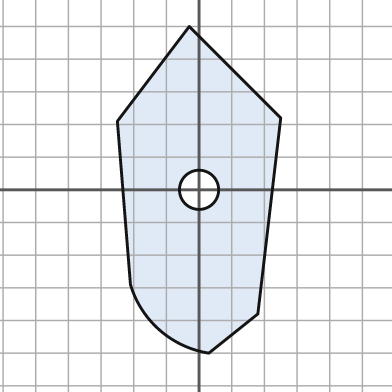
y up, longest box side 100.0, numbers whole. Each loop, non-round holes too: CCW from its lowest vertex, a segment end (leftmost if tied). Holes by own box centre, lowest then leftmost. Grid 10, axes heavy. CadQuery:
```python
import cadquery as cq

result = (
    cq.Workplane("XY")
    .moveTo(3.0, -50.0)
    .lineTo(18.0, -38.0)
    .lineTo(25.0, 22.0)
    .lineTo(-3.0, 50.0)
    .lineTo(-25.0, 21.0)
    .lineTo(-21.0, -29.0)
    .threePointArc((-12.0, -43.0), (3.0, -50.0))
    .close()
    .moveTo(0.0, 0.0)
    .circle(6.0)
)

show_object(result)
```